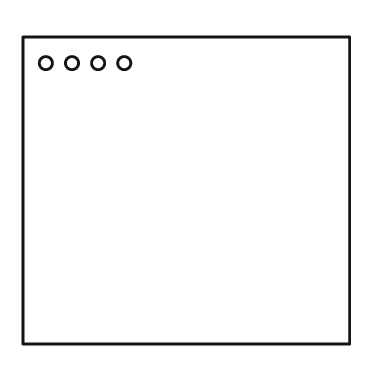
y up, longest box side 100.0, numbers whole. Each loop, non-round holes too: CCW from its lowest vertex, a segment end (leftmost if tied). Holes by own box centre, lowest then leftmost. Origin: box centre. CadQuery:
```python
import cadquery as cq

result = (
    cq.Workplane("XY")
    .moveTo(-50.0, -47.0)
    .lineTo(50.0, -47.0)
    .lineTo(50.0, 47.0)
    .lineTo(-50.0, 47.0)
    .close()
    .moveTo(-43.0, 39.0)
    .circle(2.0)
    .moveTo(-35.0, 39.0)
    .circle(2.0)
    .moveTo(-27.0, 39.0)
    .circle(2.0)
    .moveTo(-19.0, 39.0)
    .circle(2.0)
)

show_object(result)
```